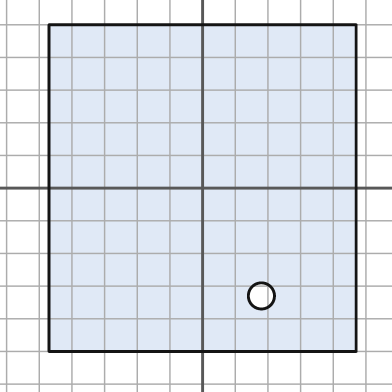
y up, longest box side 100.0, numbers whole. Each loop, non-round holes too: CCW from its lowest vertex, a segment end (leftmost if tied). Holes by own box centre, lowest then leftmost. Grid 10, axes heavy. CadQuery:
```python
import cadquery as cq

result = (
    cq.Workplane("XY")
    .moveTo(-47.0, -50.0)
    .lineTo(47.0, -50.0)
    .lineTo(47.0, 50.0)
    .lineTo(-47.0, 50.0)
    .close()
    .moveTo(18.0, -33.0)
    .circle(4.0)
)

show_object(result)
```